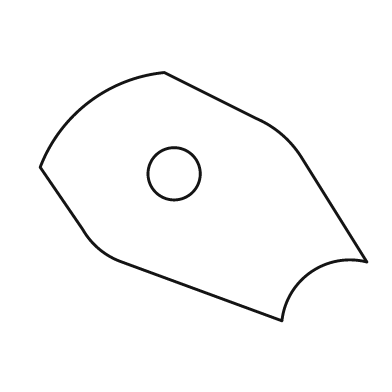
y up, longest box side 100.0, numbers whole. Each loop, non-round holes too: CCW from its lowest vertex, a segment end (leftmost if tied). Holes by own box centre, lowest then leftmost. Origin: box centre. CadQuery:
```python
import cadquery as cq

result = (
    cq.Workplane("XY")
    .moveTo(24.0, -38.0)
    .threePointArc((33.0, -23.0), (50.0, -20.0))
    .lineTo(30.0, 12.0)
    .threePointArc((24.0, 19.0), (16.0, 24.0))
    .lineTo(-12.0, 38.0)
    .threePointArc((-35.0, 29.0), (-50.0, 9.0))
    .lineTo(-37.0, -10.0)
    .threePointArc((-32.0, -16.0), (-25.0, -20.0))
    .close()
    .moveTo(-9.0, 7.0)
    .circle(8.0)
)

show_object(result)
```